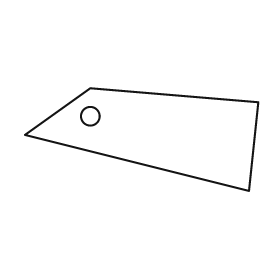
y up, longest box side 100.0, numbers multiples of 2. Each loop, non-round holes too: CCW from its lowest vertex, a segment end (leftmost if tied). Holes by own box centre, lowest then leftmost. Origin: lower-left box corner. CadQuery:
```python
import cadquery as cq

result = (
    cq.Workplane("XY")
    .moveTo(96.0, 0.0)
    .lineTo(100.0, 38.0)
    .lineTo(28.0, 44.0)
    .lineTo(0.0, 24.0)
    .close()
    .moveTo(28.0, 32.0)
    .circle(4.0)
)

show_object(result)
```